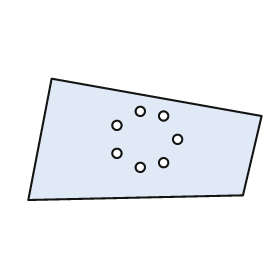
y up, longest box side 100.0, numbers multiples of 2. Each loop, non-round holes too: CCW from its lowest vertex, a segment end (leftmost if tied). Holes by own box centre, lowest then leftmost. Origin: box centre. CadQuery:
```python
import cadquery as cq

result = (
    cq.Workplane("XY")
    .moveTo(-50.0, -26.0)
    .lineTo(42.0, -24.0)
    .lineTo(50.0, 10.0)
    .lineTo(-40.0, 26.0)
    .close()
    .moveTo(-2.0, -12.0)
    .circle(2.0)
    .moveTo(8.0, -10.0)
    .circle(2.0)
    .moveTo(-12.0, -6.0)
    .circle(2.0)
    .moveTo(14.0, 0.0)
    .circle(2.0)
    .moveTo(-12.0, 6.0)
    .circle(2.0)
    .moveTo(8.0, 10.0)
    .circle(2.0)
    .moveTo(-2.0, 12.0)
    .circle(2.0)
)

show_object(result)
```